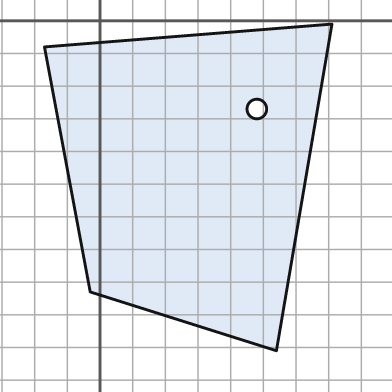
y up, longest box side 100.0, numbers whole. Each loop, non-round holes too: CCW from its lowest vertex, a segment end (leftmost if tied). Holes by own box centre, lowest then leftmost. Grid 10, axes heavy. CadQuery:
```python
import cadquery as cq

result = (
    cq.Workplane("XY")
    .moveTo(54.0, -101.0)
    .lineTo(71.0, -1.0)
    .lineTo(-17.0, -8.0)
    .lineTo(-3.0, -83.0)
    .close()
    .moveTo(48.0, -27.0)
    .circle(3.0)
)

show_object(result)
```